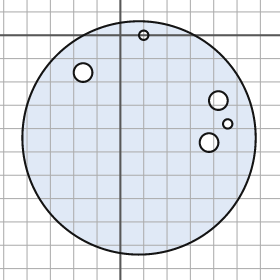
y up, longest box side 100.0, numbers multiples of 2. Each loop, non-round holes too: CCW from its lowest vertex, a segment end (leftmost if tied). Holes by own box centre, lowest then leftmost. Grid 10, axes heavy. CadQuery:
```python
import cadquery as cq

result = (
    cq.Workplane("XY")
    .moveTo(8.0, -44.0)
    .circle(50.0)
    .moveTo(38.0, -46.0)
    .circle(4.0)
    .moveTo(46.0, -38.0)
    .circle(2.0)
    .moveTo(42.0, -28.0)
    .circle(4.0)
    .moveTo(-16.0, -16.0)
    .circle(4.0)
    .moveTo(10.0, 0.0)
    .circle(2.0)
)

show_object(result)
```